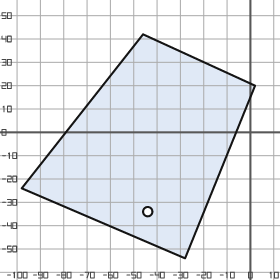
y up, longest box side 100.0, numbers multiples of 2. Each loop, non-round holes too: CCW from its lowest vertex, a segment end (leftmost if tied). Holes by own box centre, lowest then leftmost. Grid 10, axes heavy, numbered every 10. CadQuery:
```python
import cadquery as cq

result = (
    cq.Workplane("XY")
    .moveTo(-28.0, -54.0)
    .lineTo(2.0, 20.0)
    .lineTo(-46.0, 42.0)
    .lineTo(-98.0, -24.0)
    .close()
    .moveTo(-44.0, -34.0)
    .circle(2.0)
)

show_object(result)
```